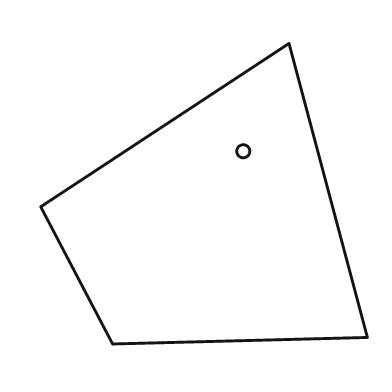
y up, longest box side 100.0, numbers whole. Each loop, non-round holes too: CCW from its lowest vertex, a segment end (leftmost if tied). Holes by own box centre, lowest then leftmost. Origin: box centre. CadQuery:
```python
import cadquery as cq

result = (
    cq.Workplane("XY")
    .moveTo(-28.0, -46.0)
    .lineTo(50.0, -44.0)
    .lineTo(26.0, 46.0)
    .lineTo(-50.0, -4.0)
    .close()
    .moveTo(12.0, 13.0)
    .circle(2.0)
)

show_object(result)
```